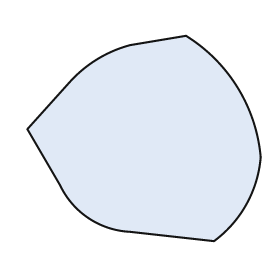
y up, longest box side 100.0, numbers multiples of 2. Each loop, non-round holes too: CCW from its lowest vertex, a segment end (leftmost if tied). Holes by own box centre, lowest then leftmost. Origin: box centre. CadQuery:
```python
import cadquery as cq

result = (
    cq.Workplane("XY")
    .moveTo(30.0, -44.0)
    .threePointArc((44.0, -28.0), (50.0, -8.0))
    .threePointArc((40.0, 22.0), (18.0, 44.0))
    .lineTo(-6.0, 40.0)
    .threePointArc((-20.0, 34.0), (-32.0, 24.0))
    .lineTo(-50.0, 4.0)
    .lineTo(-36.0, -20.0)
    .threePointArc((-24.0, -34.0), (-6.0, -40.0))
    .close()
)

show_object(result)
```